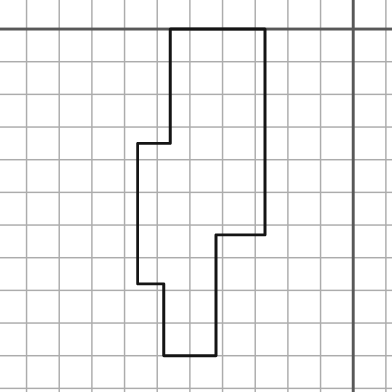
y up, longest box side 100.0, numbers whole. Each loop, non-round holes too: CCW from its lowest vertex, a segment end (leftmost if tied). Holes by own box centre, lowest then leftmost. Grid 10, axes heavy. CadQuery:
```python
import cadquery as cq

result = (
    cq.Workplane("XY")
    .moveTo(-58.0, -100.0)
    .lineTo(-42.0, -100.0)
    .lineTo(-42.0, -63.0)
    .lineTo(-27.0, -63.0)
    .lineTo(-27.0, 0.0)
    .lineTo(-56.0, 0.0)
    .lineTo(-56.0, -35.0)
    .lineTo(-66.0, -35.0)
    .lineTo(-66.0, -78.0)
    .lineTo(-58.0, -78.0)
    .close()
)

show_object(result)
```